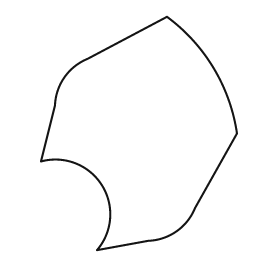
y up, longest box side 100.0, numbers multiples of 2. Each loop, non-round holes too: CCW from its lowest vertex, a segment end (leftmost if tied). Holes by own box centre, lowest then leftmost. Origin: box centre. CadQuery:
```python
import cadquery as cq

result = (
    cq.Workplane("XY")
    .moveTo(-18.0, -50.0)
    .lineTo(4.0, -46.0)
    .threePointArc((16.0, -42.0), (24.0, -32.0))
    .lineTo(42.0, 0.0)
    .threePointArc((32.0, 28.0), (12.0, 50.0))
    .lineTo(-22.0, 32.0)
    .threePointArc((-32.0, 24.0), (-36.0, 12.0))
    .lineTo(-42.0, -12.0)
    .threePointArc((-16.0, -22.0), (-18.0, -50.0))
    .close()
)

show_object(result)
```